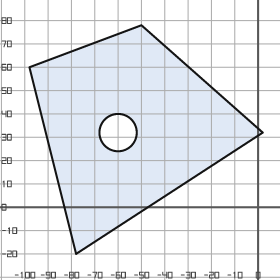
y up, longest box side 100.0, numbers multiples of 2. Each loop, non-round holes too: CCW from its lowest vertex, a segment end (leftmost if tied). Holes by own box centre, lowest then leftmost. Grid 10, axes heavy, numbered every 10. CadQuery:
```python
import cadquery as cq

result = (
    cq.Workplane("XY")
    .moveTo(-78.0, -20.0)
    .lineTo(2.0, 32.0)
    .lineTo(-50.0, 78.0)
    .lineTo(-98.0, 60.0)
    .close()
    .moveTo(-60.0, 32.0)
    .circle(8.0)
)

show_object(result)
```